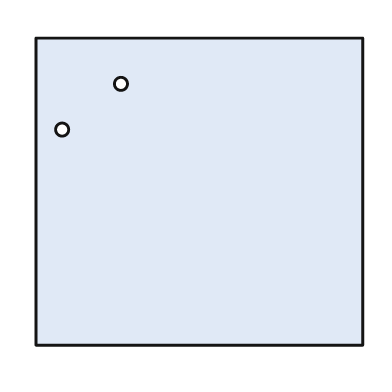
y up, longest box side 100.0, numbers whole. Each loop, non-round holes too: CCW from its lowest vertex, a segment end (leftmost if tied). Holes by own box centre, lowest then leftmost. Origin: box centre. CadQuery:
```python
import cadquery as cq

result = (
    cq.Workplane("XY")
    .moveTo(-50.0, -47.0)
    .lineTo(50.0, -47.0)
    .lineTo(50.0, 47.0)
    .lineTo(-50.0, 47.0)
    .close()
    .moveTo(-42.0, 19.0)
    .circle(2.0)
    .moveTo(-24.0, 33.0)
    .circle(2.0)
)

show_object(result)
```